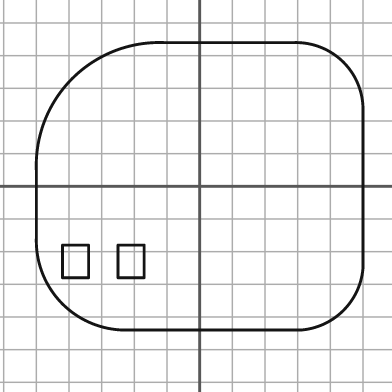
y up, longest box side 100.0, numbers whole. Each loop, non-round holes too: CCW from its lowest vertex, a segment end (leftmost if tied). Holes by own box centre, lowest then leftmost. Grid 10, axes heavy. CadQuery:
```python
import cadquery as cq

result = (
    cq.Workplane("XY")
    .moveTo(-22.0, -44.0)
    .lineTo(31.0, -44.0)
    .threePointArc((44.0, -38.0), (50.0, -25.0))
    .lineTo(50.0, 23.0)
    .threePointArc((44.0, 38.0), (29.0, 44.0))
    .lineTo(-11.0, 44.0)
    .threePointArc((-39.0, 33.0), (-50.0, 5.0))
    .lineTo(-50.0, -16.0)
    .threePointArc((-42.0, -36.0), (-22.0, -44.0))
    .close()
    .moveTo(-42.0, -28.0)
    .lineTo(-34.0, -28.0)
    .lineTo(-34.0, -18.0)
    .lineTo(-42.0, -18.0)
    .close()
    .moveTo(-25.0, -28.0)
    .lineTo(-17.0, -28.0)
    .lineTo(-17.0, -18.0)
    .lineTo(-25.0, -18.0)
    .close()
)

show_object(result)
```